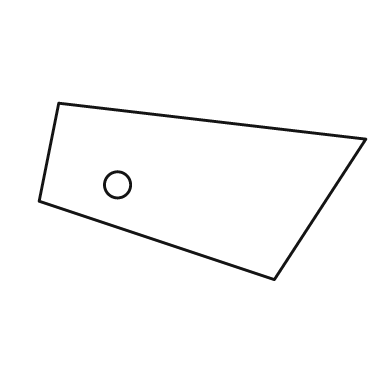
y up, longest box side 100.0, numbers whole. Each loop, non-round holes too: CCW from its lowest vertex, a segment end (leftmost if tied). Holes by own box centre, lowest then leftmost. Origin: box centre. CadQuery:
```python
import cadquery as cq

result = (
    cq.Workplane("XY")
    .moveTo(22.0, -27.0)
    .lineTo(50.0, 16.0)
    .lineTo(-44.0, 27.0)
    .lineTo(-50.0, -3.0)
    .close()
    .moveTo(-26.0, 2.0)
    .circle(4.0)
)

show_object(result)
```